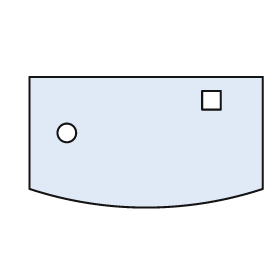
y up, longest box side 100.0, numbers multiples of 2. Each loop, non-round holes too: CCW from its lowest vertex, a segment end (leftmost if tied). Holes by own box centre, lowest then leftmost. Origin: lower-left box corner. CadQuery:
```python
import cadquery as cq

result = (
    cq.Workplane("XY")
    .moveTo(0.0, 8.0)
    .threePointArc((50.0, 0.0), (100.0, 8.0))
    .lineTo(100.0, 56.0)
    .lineTo(0.0, 56.0)
    .close()
    .moveTo(16.0, 32.0)
    .circle(4.0)
    .moveTo(74.0, 42.0)
    .lineTo(82.0, 42.0)
    .lineTo(82.0, 50.0)
    .lineTo(74.0, 50.0)
    .close()
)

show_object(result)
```